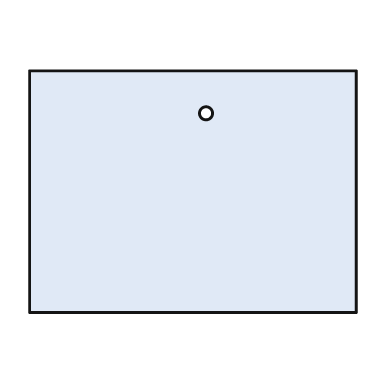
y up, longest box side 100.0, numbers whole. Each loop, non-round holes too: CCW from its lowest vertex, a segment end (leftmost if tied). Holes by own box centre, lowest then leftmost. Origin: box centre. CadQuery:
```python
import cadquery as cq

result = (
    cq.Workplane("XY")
    .moveTo(-50.0, -37.0)
    .lineTo(50.0, -37.0)
    .lineTo(50.0, 37.0)
    .lineTo(-50.0, 37.0)
    .close()
    .moveTo(4.0, 24.0)
    .circle(2.0)
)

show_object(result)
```